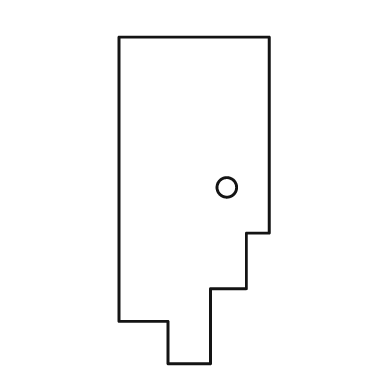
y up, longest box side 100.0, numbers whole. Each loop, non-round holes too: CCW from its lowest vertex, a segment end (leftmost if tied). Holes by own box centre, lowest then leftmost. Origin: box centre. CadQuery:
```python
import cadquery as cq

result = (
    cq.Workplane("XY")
    .moveTo(-8.0, -50.0)
    .lineTo(5.0, -50.0)
    .lineTo(5.0, -27.0)
    .lineTo(16.0, -27.0)
    .lineTo(16.0, -10.0)
    .lineTo(23.0, -10.0)
    .lineTo(23.0, 50.0)
    .lineTo(-23.0, 50.0)
    .lineTo(-23.0, -37.0)
    .lineTo(-8.0, -37.0)
    .close()
    .moveTo(10.0, 4.0)
    .circle(3.0)
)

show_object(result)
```